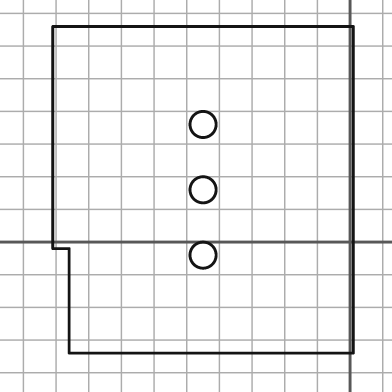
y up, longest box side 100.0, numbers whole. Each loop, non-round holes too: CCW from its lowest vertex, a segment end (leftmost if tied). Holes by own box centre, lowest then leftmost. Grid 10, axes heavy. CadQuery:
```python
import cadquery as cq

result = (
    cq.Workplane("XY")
    .moveTo(-86.0, -34.0)
    .lineTo(1.0, -34.0)
    .lineTo(1.0, 66.0)
    .lineTo(-91.0, 66.0)
    .lineTo(-91.0, -2.0)
    .lineTo(-86.0, -2.0)
    .close()
    .moveTo(-45.0, -4.0)
    .circle(4.0)
    .moveTo(-45.0, 16.0)
    .circle(4.0)
    .moveTo(-45.0, 36.0)
    .circle(4.0)
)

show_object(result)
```